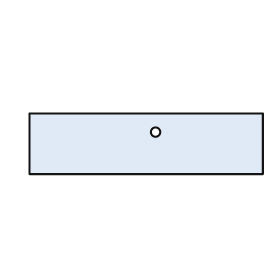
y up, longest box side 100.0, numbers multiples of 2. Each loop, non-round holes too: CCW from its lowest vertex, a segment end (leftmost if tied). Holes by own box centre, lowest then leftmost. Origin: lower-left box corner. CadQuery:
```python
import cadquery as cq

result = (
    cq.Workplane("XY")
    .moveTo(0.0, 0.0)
    .lineTo(100.0, 0.0)
    .lineTo(100.0, 26.0)
    .lineTo(0.0, 26.0)
    .close()
    .moveTo(54.0, 18.0)
    .circle(2.0)
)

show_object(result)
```